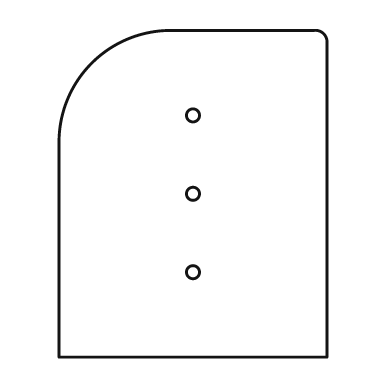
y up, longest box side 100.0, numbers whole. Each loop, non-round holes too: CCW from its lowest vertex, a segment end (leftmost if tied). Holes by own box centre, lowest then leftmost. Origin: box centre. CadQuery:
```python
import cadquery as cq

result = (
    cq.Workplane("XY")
    .moveTo(-41.0, -50.0)
    .lineTo(41.0, -50.0)
    .lineTo(41.0, 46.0)
    .threePointArc((40.0, 49.0), (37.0, 50.0))
    .lineTo(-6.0, 50.0)
    .threePointArc((-31.0, 40.0), (-41.0, 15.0))
    .close()
    .moveTo(0.0, -24.0)
    .circle(2.0)
    .moveTo(0.0, 0.0)
    .circle(2.0)
    .moveTo(0.0, 24.0)
    .circle(2.0)
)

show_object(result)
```